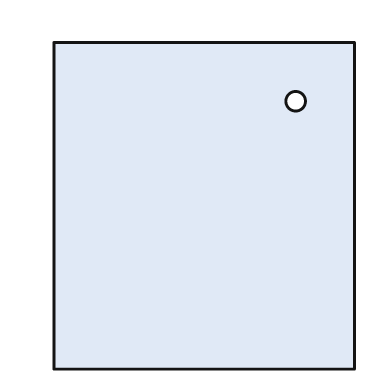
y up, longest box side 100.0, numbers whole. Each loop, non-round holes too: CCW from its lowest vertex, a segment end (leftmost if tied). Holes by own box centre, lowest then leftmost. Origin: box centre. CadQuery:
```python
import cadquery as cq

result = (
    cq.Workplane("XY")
    .moveTo(-46.0, -50.0)
    .lineTo(46.0, -50.0)
    .lineTo(46.0, 50.0)
    .lineTo(-46.0, 50.0)
    .close()
    .moveTo(28.0, 32.0)
    .circle(3.0)
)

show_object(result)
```